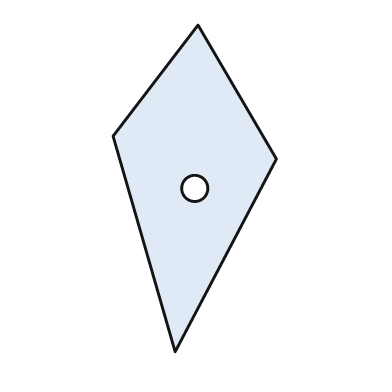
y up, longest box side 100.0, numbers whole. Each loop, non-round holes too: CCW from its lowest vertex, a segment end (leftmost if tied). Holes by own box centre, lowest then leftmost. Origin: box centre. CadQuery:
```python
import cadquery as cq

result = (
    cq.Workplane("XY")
    .moveTo(-6.0, -50.0)
    .lineTo(25.0, 9.0)
    .lineTo(1.0, 50.0)
    .lineTo(-25.0, 16.0)
    .close()
    .moveTo(0.0, 0.0)
    .circle(4.0)
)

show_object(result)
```